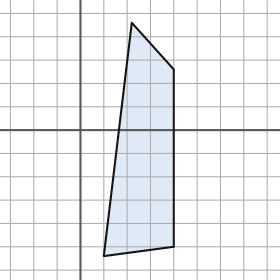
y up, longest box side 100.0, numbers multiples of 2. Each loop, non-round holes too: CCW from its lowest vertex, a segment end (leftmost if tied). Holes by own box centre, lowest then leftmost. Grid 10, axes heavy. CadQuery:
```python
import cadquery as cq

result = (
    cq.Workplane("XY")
    .moveTo(10.0, -54.0)
    .lineTo(40.0, -50.0)
    .lineTo(40.0, 26.0)
    .lineTo(22.0, 46.0)
    .close()
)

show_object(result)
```